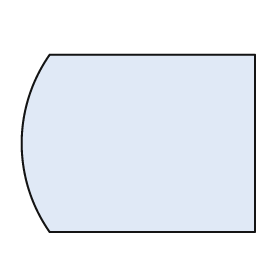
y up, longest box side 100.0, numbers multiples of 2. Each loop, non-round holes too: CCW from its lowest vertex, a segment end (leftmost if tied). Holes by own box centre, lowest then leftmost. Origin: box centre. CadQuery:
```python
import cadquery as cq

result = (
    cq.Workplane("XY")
    .moveTo(-38.0, -38.0)
    .lineTo(50.0, -38.0)
    .lineTo(50.0, 38.0)
    .lineTo(-38.0, 38.0)
    .threePointArc((-50.0, 0.0), (-38.0, -38.0))
    .close()
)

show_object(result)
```